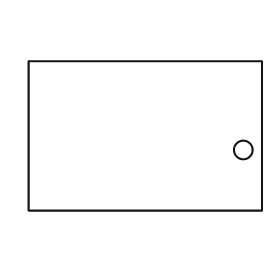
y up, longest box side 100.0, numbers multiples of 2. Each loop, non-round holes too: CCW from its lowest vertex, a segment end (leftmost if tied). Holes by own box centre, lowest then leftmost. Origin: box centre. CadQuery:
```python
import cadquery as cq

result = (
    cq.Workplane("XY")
    .moveTo(-50.0, -32.0)
    .lineTo(50.0, -32.0)
    .lineTo(50.0, 32.0)
    .lineTo(-50.0, 32.0)
    .close()
    .moveTo(42.0, -6.0)
    .circle(4.0)
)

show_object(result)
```